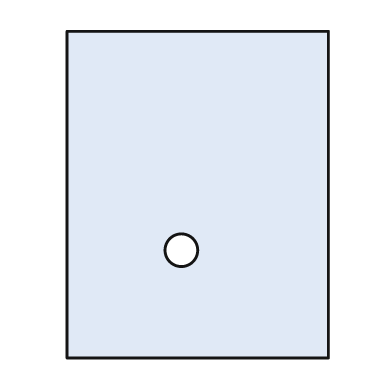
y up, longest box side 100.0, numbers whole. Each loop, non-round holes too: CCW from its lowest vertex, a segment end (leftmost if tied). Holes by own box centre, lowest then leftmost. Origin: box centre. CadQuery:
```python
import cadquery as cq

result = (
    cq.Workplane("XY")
    .moveTo(-40.0, -50.0)
    .lineTo(40.0, -50.0)
    .lineTo(40.0, 50.0)
    .lineTo(-40.0, 50.0)
    .close()
    .moveTo(-5.0, -17.0)
    .circle(5.0)
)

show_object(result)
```